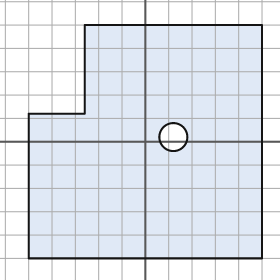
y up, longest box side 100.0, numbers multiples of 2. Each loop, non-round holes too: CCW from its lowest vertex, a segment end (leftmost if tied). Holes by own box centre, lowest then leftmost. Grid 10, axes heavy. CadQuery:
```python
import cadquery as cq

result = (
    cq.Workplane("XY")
    .moveTo(-50.0, -50.0)
    .lineTo(50.0, -50.0)
    .lineTo(50.0, 50.0)
    .lineTo(-26.0, 50.0)
    .lineTo(-26.0, 12.0)
    .lineTo(-50.0, 12.0)
    .close()
    .moveTo(12.0, 2.0)
    .circle(6.0)
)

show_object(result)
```